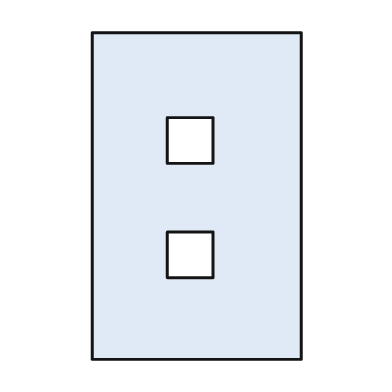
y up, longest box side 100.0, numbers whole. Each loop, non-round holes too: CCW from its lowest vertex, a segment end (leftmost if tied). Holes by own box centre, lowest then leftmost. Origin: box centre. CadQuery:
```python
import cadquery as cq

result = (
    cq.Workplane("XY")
    .moveTo(-32.0, -50.0)
    .lineTo(32.0, -50.0)
    .lineTo(32.0, 50.0)
    .lineTo(-32.0, 50.0)
    .close()
    .moveTo(-9.0, -25.0)
    .lineTo(5.0, -25.0)
    .lineTo(5.0, -11.0)
    .lineTo(-9.0, -11.0)
    .close()
    .moveTo(-9.0, 10.0)
    .lineTo(5.0, 10.0)
    .lineTo(5.0, 24.0)
    .lineTo(-9.0, 24.0)
    .close()
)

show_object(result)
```